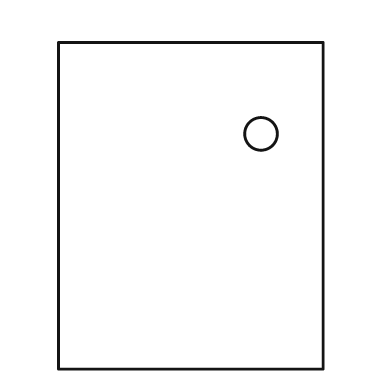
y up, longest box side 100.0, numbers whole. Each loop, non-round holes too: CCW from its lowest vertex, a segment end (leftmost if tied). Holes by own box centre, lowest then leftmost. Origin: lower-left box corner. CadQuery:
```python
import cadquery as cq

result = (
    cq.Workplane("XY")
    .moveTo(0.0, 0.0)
    .lineTo(81.0, 0.0)
    .lineTo(81.0, 100.0)
    .lineTo(0.0, 100.0)
    .close()
    .moveTo(62.0, 72.0)
    .circle(5.0)
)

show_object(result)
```